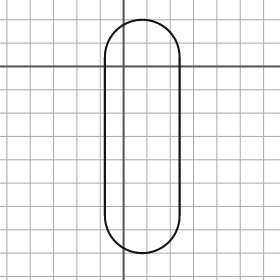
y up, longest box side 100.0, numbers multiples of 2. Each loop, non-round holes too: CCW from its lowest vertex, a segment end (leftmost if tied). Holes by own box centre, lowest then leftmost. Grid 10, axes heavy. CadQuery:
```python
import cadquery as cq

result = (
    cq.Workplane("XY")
    .moveTo(-8.0, -64.0)
    .threePointArc((8.0, -80.0), (24.0, -64.0))
    .lineTo(24.0, 4.0)
    .threePointArc((8.0, 20.0), (-8.0, 4.0))
    .close()
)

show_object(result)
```